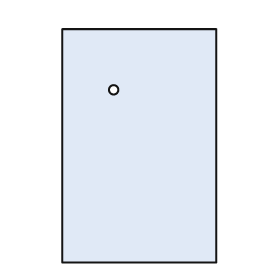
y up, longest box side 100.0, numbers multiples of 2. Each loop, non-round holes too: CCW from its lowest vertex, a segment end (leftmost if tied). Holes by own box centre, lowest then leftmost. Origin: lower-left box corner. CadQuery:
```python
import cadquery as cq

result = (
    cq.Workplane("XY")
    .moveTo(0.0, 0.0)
    .lineTo(66.0, 0.0)
    .lineTo(66.0, 100.0)
    .lineTo(0.0, 100.0)
    .close()
    .moveTo(22.0, 74.0)
    .circle(2.0)
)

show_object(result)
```